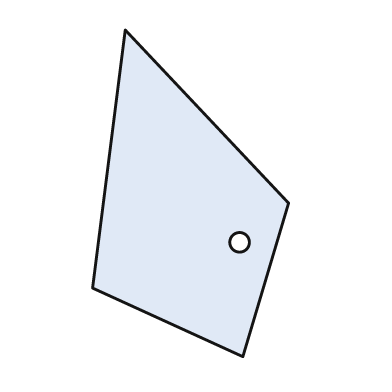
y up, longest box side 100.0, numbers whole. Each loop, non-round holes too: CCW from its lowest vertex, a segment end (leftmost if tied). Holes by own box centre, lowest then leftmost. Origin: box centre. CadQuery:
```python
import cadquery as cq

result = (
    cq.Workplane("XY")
    .moveTo(16.0, -50.0)
    .lineTo(30.0, -3.0)
    .lineTo(-20.0, 50.0)
    .lineTo(-30.0, -29.0)
    .close()
    .moveTo(15.0, -15.0)
    .circle(3.0)
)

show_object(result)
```